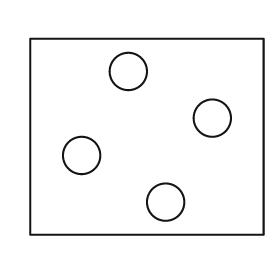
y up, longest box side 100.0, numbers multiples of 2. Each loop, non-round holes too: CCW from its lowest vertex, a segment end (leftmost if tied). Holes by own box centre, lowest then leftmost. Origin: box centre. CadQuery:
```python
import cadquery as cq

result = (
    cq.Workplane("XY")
    .moveTo(-50.0, -42.0)
    .lineTo(50.0, -42.0)
    .lineTo(50.0, 42.0)
    .lineTo(-50.0, 42.0)
    .close()
    .moveTo(8.0, -28.0)
    .circle(8.0)
    .moveTo(-28.0, -8.0)
    .circle(8.0)
    .moveTo(28.0, 8.0)
    .circle(8.0)
    .moveTo(-8.0, 28.0)
    .circle(8.0)
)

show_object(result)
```